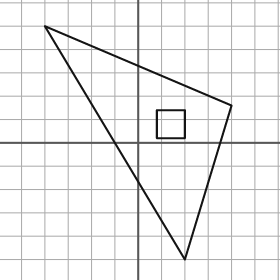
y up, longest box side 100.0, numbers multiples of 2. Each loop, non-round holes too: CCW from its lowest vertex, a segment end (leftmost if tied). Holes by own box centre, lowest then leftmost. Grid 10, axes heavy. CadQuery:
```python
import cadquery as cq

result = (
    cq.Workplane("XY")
    .moveTo(20.0, -50.0)
    .lineTo(40.0, 16.0)
    .lineTo(-40.0, 50.0)
    .close()
    .moveTo(8.0, 2.0)
    .lineTo(20.0, 2.0)
    .lineTo(20.0, 14.0)
    .lineTo(8.0, 14.0)
    .close()
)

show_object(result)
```